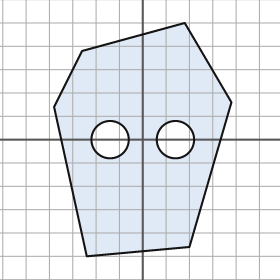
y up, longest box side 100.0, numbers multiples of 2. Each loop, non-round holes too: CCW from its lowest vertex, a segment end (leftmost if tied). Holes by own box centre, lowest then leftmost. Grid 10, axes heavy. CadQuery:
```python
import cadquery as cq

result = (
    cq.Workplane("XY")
    .moveTo(-24.0, -50.0)
    .lineTo(20.0, -46.0)
    .lineTo(38.0, 16.0)
    .lineTo(18.0, 50.0)
    .lineTo(-26.0, 38.0)
    .lineTo(-38.0, 14.0)
    .close()
    .moveTo(-14.0, 0.0)
    .circle(8.0)
    .moveTo(14.0, 0.0)
    .circle(8.0)
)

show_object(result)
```